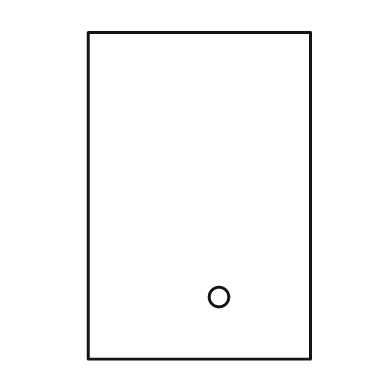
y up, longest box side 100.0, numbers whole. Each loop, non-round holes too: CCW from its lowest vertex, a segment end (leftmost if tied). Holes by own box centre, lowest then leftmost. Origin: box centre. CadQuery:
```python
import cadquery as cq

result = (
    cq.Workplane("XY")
    .moveTo(-34.0, -50.0)
    .lineTo(34.0, -50.0)
    .lineTo(34.0, 50.0)
    .lineTo(-34.0, 50.0)
    .close()
    .moveTo(6.0, -31.0)
    .circle(3.0)
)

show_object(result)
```